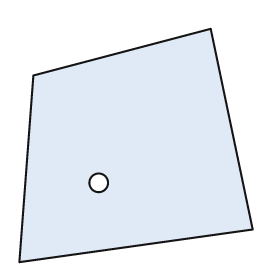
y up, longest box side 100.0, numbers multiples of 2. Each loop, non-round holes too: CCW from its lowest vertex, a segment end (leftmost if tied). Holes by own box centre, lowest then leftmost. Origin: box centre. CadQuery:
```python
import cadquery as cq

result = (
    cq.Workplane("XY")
    .moveTo(-50.0, -50.0)
    .lineTo(50.0, -36.0)
    .lineTo(32.0, 50.0)
    .lineTo(-44.0, 30.0)
    .close()
    .moveTo(-16.0, -16.0)
    .circle(4.0)
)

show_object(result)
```